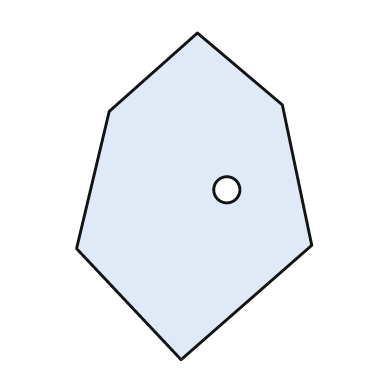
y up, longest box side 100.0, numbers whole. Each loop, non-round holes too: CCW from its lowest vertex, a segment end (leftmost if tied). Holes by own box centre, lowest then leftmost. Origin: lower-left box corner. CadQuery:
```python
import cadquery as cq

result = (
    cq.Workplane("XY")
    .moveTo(32.0, 0.0)
    .lineTo(72.0, 35.0)
    .lineTo(63.0, 78.0)
    .lineTo(37.0, 100.0)
    .lineTo(10.0, 76.0)
    .lineTo(0.0, 34.0)
    .close()
    .moveTo(46.0, 52.0)
    .circle(4.0)
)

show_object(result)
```